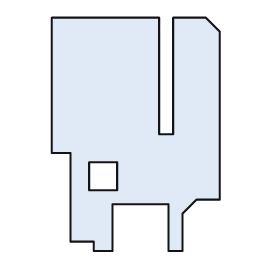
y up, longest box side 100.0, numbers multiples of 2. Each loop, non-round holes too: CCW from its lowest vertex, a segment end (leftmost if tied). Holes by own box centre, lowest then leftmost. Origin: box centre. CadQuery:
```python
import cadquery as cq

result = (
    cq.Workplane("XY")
    .moveTo(-18.0, -50.0)
    .lineTo(-10.0, -50.0)
    .lineTo(-10.0, -30.0)
    .lineTo(14.0, -30.0)
    .lineTo(14.0, -50.0)
    .lineTo(20.0, -50.0)
    .lineTo(20.0, -34.0)
    .lineTo(26.0, -28.0)
    .lineTo(36.0, -28.0)
    .lineTo(36.0, 44.0)
    .lineTo(30.0, 50.0)
    .lineTo(16.0, 50.0)
    .lineTo(16.0, 0.0)
    .lineTo(10.0, 0.0)
    .lineTo(10.0, 50.0)
    .lineTo(-36.0, 50.0)
    .lineTo(-36.0, -8.0)
    .lineTo(-28.0, -8.0)
    .lineTo(-28.0, -46.0)
    .lineTo(-18.0, -46.0)
    .close()
    .moveTo(-20.0, -24.0)
    .lineTo(-8.0, -24.0)
    .lineTo(-8.0, -12.0)
    .lineTo(-20.0, -12.0)
    .close()
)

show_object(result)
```